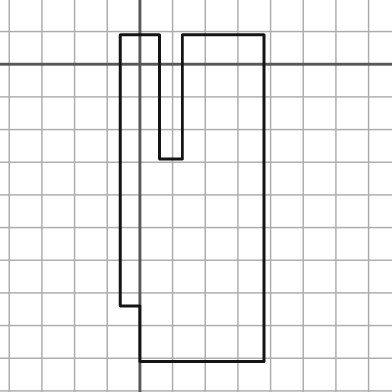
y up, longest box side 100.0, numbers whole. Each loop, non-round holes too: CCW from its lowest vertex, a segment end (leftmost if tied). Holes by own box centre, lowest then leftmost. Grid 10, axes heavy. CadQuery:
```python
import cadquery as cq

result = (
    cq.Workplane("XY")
    .moveTo(0.0, -91.0)
    .lineTo(38.0, -91.0)
    .lineTo(38.0, 9.0)
    .lineTo(13.0, 9.0)
    .lineTo(13.0, -29.0)
    .lineTo(6.0, -29.0)
    .lineTo(6.0, 9.0)
    .lineTo(-6.0, 9.0)
    .lineTo(-6.0, -74.0)
    .lineTo(0.0, -74.0)
    .close()
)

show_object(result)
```